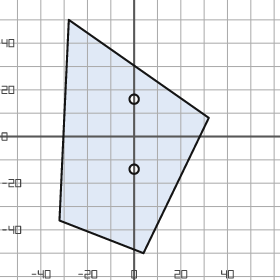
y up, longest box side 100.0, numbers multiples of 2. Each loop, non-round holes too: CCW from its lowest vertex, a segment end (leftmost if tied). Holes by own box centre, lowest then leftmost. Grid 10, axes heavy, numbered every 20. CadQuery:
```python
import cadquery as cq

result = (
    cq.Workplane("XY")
    .moveTo(4.0, -50.0)
    .lineTo(32.0, 8.0)
    .lineTo(-28.0, 50.0)
    .lineTo(-32.0, -36.0)
    .close()
    .moveTo(0.0, -14.0)
    .circle(2.0)
    .moveTo(0.0, 16.0)
    .circle(2.0)
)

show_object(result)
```